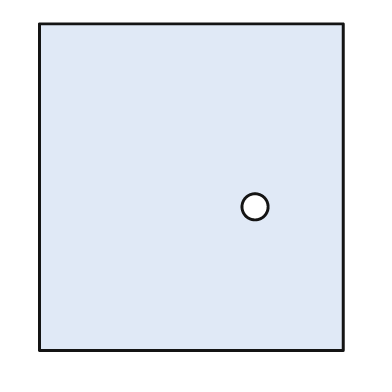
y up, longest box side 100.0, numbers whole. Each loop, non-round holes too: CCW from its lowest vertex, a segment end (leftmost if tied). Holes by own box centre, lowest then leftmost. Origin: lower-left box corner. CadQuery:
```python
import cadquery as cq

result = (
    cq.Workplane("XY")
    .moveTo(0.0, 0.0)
    .lineTo(93.0, 0.0)
    .lineTo(93.0, 100.0)
    .lineTo(0.0, 100.0)
    .close()
    .moveTo(66.0, 44.0)
    .circle(4.0)
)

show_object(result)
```